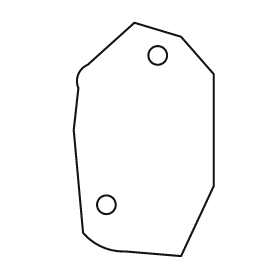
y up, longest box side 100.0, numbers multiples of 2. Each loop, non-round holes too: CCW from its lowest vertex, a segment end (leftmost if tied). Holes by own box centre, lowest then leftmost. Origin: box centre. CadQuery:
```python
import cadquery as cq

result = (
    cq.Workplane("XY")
    .moveTo(16.0, -50.0)
    .lineTo(30.0, -20.0)
    .lineTo(30.0, 28.0)
    .lineTo(16.0, 44.0)
    .lineTo(-4.0, 50.0)
    .lineTo(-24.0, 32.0)
    .threePointArc((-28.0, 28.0), (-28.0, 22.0))
    .lineTo(-30.0, 4.0)
    .lineTo(-26.0, -40.0)
    .threePointArc((-18.0, -46.0), (-8.0, -48.0))
    .close()
    .moveTo(-16.0, -28.0)
    .circle(4.0)
    .moveTo(6.0, 36.0)
    .circle(4.0)
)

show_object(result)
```